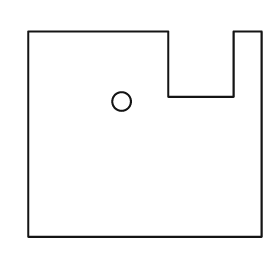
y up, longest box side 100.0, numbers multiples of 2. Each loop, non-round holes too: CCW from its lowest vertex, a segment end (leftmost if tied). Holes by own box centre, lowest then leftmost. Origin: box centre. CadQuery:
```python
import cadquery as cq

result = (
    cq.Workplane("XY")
    .moveTo(-50.0, -44.0)
    .lineTo(50.0, -44.0)
    .lineTo(50.0, 44.0)
    .lineTo(38.0, 44.0)
    .lineTo(38.0, 16.0)
    .lineTo(10.0, 16.0)
    .lineTo(10.0, 44.0)
    .lineTo(-50.0, 44.0)
    .close()
    .moveTo(-10.0, 14.0)
    .circle(4.0)
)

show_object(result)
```